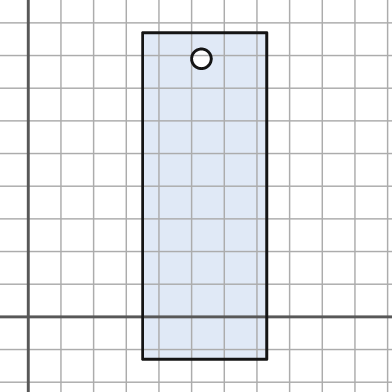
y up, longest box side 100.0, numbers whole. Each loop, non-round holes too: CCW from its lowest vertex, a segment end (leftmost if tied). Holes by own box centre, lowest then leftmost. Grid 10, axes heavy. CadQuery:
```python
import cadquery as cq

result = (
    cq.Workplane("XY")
    .moveTo(35.0, -13.0)
    .lineTo(73.0, -13.0)
    .lineTo(73.0, 87.0)
    .lineTo(35.0, 87.0)
    .close()
    .moveTo(53.0, 79.0)
    .circle(3.0)
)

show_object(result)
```